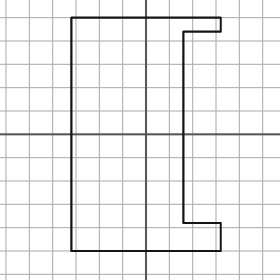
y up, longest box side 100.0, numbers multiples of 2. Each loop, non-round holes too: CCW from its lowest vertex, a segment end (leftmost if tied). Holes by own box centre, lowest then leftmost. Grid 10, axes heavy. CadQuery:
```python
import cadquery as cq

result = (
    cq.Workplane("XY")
    .moveTo(-32.0, -50.0)
    .lineTo(32.0, -50.0)
    .lineTo(32.0, -38.0)
    .lineTo(16.0, -38.0)
    .lineTo(16.0, 44.0)
    .lineTo(32.0, 44.0)
    .lineTo(32.0, 50.0)
    .lineTo(-32.0, 50.0)
    .close()
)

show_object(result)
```